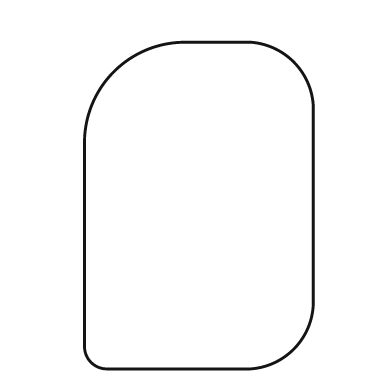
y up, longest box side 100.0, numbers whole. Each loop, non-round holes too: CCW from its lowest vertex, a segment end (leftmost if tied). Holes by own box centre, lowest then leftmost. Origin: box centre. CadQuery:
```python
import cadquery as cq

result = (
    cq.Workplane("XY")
    .moveTo(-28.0, -50.0)
    .lineTo(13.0, -50.0)
    .threePointArc((29.0, -44.0), (35.0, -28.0))
    .lineTo(35.0, 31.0)
    .threePointArc((29.0, 44.0), (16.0, 50.0))
    .lineTo(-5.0, 50.0)
    .threePointArc((-26.0, 41.0), (-35.0, 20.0))
    .lineTo(-35.0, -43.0)
    .threePointArc((-33.0, -48.0), (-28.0, -50.0))
    .close()
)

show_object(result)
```